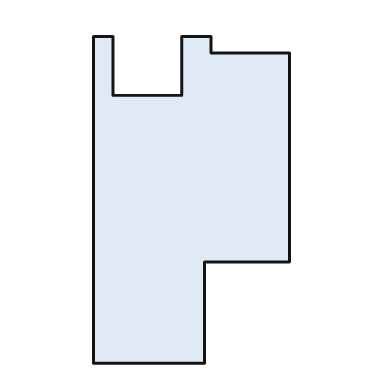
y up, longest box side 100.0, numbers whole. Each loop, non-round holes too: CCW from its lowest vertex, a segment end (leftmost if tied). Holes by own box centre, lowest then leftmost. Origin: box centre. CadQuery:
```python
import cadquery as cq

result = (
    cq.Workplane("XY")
    .moveTo(-30.0, -50.0)
    .lineTo(4.0, -50.0)
    .lineTo(4.0, -19.0)
    .lineTo(30.0, -19.0)
    .lineTo(30.0, 45.0)
    .lineTo(6.0, 45.0)
    .lineTo(6.0, 50.0)
    .lineTo(-3.0, 50.0)
    .lineTo(-3.0, 32.0)
    .lineTo(-24.0, 32.0)
    .lineTo(-24.0, 50.0)
    .lineTo(-30.0, 50.0)
    .close()
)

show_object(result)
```